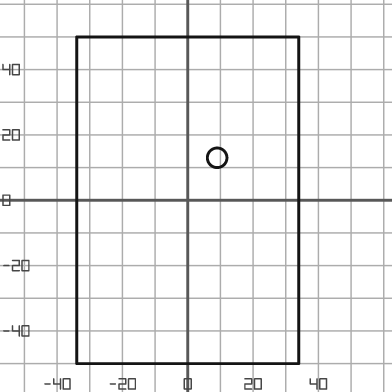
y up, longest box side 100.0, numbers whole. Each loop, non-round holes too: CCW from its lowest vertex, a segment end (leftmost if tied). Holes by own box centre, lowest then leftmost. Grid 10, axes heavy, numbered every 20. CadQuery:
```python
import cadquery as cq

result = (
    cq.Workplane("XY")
    .moveTo(-34.0, -50.0)
    .lineTo(34.0, -50.0)
    .lineTo(34.0, 50.0)
    .lineTo(-34.0, 50.0)
    .close()
    .moveTo(9.0, 13.0)
    .circle(3.0)
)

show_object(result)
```